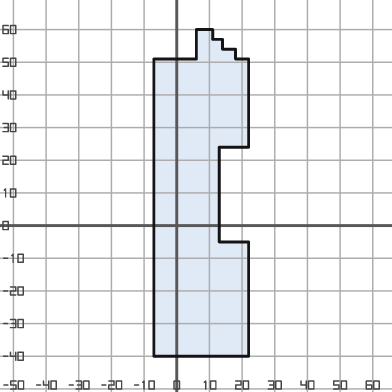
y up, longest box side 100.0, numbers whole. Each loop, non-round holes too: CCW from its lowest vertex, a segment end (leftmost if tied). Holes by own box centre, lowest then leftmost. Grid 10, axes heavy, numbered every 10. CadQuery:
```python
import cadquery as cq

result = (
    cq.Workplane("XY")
    .moveTo(-7.0, -40.0)
    .lineTo(22.0, -40.0)
    .lineTo(22.0, -5.0)
    .lineTo(13.0, -5.0)
    .lineTo(13.0, 24.0)
    .lineTo(22.0, 24.0)
    .lineTo(22.0, 51.0)
    .lineTo(18.0, 51.0)
    .lineTo(18.0, 54.0)
    .lineTo(14.0, 54.0)
    .lineTo(14.0, 57.0)
    .lineTo(11.0, 57.0)
    .lineTo(11.0, 60.0)
    .lineTo(6.0, 60.0)
    .lineTo(6.0, 51.0)
    .lineTo(-7.0, 51.0)
    .close()
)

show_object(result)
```